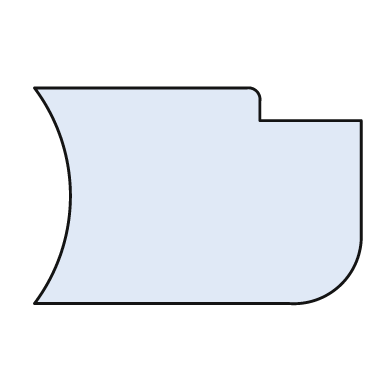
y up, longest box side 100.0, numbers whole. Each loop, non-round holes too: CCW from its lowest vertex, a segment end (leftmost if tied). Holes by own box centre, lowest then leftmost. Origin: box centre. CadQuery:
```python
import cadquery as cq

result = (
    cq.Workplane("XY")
    .moveTo(-50.0, -33.0)
    .lineTo(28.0, -33.0)
    .threePointArc((44.0, -27.0), (50.0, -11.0))
    .lineTo(50.0, 23.0)
    .lineTo(19.0, 23.0)
    .lineTo(19.0, 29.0)
    .threePointArc((18.0, 32.0), (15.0, 33.0))
    .lineTo(-50.0, 33.0)
    .threePointArc((-39.0, 0.0), (-50.0, -33.0))
    .close()
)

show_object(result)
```